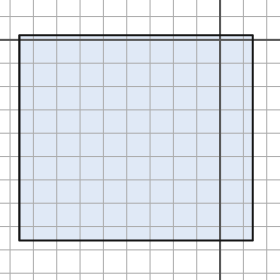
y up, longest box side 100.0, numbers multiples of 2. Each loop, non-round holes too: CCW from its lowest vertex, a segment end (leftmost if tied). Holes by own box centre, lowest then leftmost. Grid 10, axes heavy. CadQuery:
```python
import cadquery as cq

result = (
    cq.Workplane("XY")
    .moveTo(-86.0, -86.0)
    .lineTo(14.0, -86.0)
    .lineTo(14.0, 2.0)
    .lineTo(-86.0, 2.0)
    .close()
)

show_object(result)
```